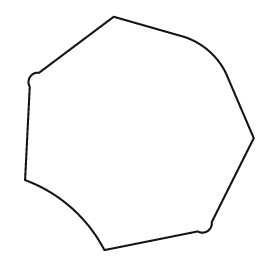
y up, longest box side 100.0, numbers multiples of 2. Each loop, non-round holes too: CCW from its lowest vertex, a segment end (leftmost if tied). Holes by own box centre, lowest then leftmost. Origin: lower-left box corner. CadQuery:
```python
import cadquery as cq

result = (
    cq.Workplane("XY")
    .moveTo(34.0, 0.0)
    .lineTo(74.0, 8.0)
    .threePointArc((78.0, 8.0), (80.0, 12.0))
    .lineTo(98.0, 48.0)
    .lineTo(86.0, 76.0)
    .threePointArc((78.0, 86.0), (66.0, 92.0))
    .lineTo(38.0, 100.0)
    .lineTo(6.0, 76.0)
    .threePointArc((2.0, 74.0), (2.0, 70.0))
    .lineTo(0.0, 30.0)
    .threePointArc((20.0, 18.0), (34.0, 0.0))
    .close()
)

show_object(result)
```